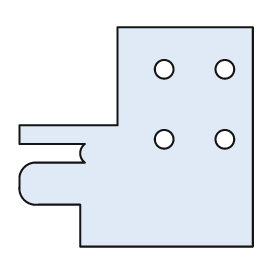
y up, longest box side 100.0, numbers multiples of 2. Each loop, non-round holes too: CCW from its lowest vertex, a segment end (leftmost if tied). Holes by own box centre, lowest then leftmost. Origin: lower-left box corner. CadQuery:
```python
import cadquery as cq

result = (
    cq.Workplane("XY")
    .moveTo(26.0, 0.0)
    .lineTo(100.0, 0.0)
    .lineTo(100.0, 94.0)
    .lineTo(42.0, 94.0)
    .lineTo(42.0, 52.0)
    .lineTo(0.0, 52.0)
    .lineTo(0.0, 44.0)
    .lineTo(28.0, 44.0)
    .threePointArc((26.0, 40.0), (28.0, 36.0))
    .lineTo(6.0, 36.0)
    .threePointArc((2.0, 34.0), (0.0, 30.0))
    .lineTo(0.0, 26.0)
    .threePointArc((2.0, 20.0), (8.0, 18.0))
    .lineTo(26.0, 18.0)
    .close()
    .moveTo(62.0, 46.0)
    .circle(4.0)
    .moveTo(88.0, 46.0)
    .circle(4.0)
    .moveTo(62.0, 76.0)
    .circle(4.0)
    .moveTo(88.0, 76.0)
    .circle(4.0)
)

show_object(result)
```